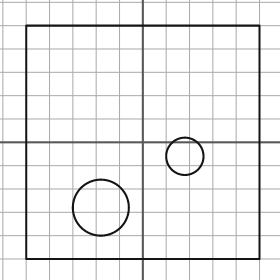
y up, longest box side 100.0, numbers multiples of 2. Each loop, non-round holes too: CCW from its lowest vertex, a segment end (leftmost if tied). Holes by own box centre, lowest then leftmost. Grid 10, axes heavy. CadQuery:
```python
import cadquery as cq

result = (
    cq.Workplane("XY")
    .moveTo(-50.0, -50.0)
    .lineTo(50.0, -50.0)
    .lineTo(50.0, 50.0)
    .lineTo(-50.0, 50.0)
    .close()
    .moveTo(-18.0, -28.0)
    .circle(12.0)
    .moveTo(18.0, -6.0)
    .circle(8.0)
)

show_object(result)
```